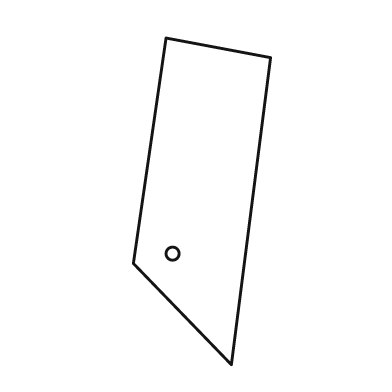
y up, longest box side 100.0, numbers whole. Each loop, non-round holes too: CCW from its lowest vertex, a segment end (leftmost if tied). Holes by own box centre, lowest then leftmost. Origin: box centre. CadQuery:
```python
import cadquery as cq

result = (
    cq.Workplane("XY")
    .moveTo(9.0, -50.0)
    .lineTo(21.0, 44.0)
    .lineTo(-11.0, 50.0)
    .lineTo(-21.0, -19.0)
    .close()
    .moveTo(-9.0, -16.0)
    .circle(2.0)
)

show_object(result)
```